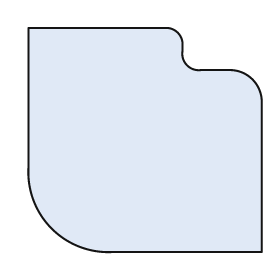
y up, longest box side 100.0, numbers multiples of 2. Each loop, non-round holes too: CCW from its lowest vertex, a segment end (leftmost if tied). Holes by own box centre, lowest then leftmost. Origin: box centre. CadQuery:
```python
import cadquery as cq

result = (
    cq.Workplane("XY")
    .moveTo(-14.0, -48.0)
    .lineTo(50.0, -48.0)
    .lineTo(50.0, 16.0)
    .threePointArc((46.0, 26.0), (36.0, 30.0))
    .lineTo(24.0, 30.0)
    .threePointArc((18.0, 32.0), (16.0, 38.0))
    .lineTo(16.0, 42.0)
    .threePointArc((14.0, 46.0), (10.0, 48.0))
    .lineTo(-50.0, 48.0)
    .lineTo(-50.0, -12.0)
    .threePointArc((-40.0, -38.0), (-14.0, -48.0))
    .close()
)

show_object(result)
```